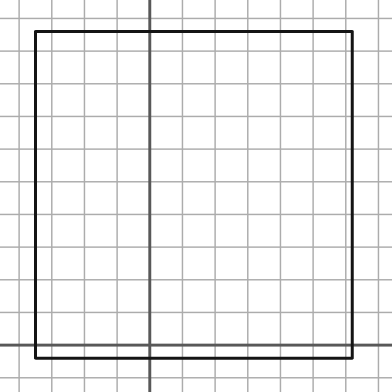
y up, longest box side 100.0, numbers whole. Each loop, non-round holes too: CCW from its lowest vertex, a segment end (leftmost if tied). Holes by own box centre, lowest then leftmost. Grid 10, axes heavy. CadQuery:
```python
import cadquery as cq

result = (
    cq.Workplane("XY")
    .moveTo(-35.0, -4.0)
    .lineTo(62.0, -4.0)
    .lineTo(62.0, 96.0)
    .lineTo(-35.0, 96.0)
    .close()
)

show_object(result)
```